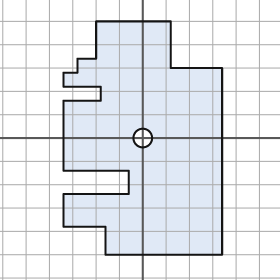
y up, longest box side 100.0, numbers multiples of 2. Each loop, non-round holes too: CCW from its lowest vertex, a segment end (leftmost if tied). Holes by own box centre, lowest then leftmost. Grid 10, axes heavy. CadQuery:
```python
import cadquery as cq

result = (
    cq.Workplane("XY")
    .moveTo(-16.0, -50.0)
    .lineTo(34.0, -50.0)
    .lineTo(34.0, 30.0)
    .lineTo(12.0, 30.0)
    .lineTo(12.0, 50.0)
    .lineTo(-20.0, 50.0)
    .lineTo(-20.0, 34.0)
    .lineTo(-28.0, 34.0)
    .lineTo(-28.0, 28.0)
    .lineTo(-34.0, 28.0)
    .lineTo(-34.0, 22.0)
    .lineTo(-18.0, 22.0)
    .lineTo(-18.0, 16.0)
    .lineTo(-34.0, 16.0)
    .lineTo(-34.0, -14.0)
    .lineTo(-6.0, -14.0)
    .lineTo(-6.0, -24.0)
    .lineTo(-34.0, -24.0)
    .lineTo(-34.0, -38.0)
    .lineTo(-16.0, -38.0)
    .close()
    .moveTo(0.0, 0.0)
    .circle(4.0)
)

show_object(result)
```